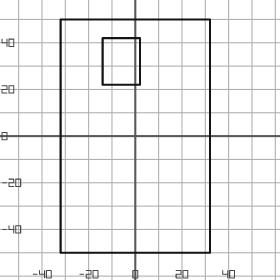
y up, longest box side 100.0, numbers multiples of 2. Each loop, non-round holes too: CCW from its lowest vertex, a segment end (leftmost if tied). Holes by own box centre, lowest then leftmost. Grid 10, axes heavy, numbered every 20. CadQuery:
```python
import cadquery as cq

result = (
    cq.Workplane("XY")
    .moveTo(-32.0, -50.0)
    .lineTo(32.0, -50.0)
    .lineTo(32.0, 50.0)
    .lineTo(-32.0, 50.0)
    .close()
    .moveTo(-14.0, 22.0)
    .lineTo(2.0, 22.0)
    .lineTo(2.0, 42.0)
    .lineTo(-14.0, 42.0)
    .close()
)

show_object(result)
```